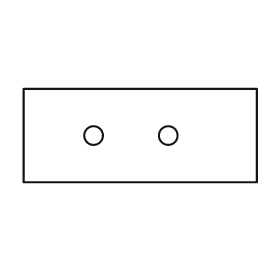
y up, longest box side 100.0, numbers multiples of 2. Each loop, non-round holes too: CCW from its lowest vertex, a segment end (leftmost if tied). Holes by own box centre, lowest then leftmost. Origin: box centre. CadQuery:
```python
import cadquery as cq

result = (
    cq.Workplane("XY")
    .moveTo(-50.0, -20.0)
    .lineTo(50.0, -20.0)
    .lineTo(50.0, 20.0)
    .lineTo(-50.0, 20.0)
    .close()
    .moveTo(-20.0, 0.0)
    .circle(4.0)
    .moveTo(12.0, 0.0)
    .circle(4.0)
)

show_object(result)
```